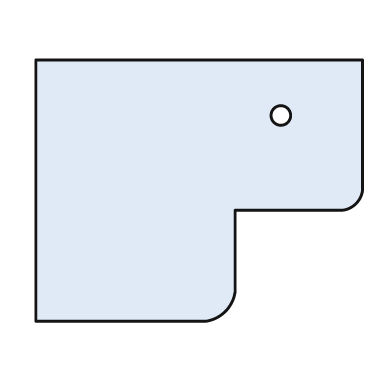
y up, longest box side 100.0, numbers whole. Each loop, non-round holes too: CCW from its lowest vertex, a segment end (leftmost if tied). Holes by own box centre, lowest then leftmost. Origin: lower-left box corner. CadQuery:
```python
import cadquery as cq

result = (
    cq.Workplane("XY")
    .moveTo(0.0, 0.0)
    .lineTo(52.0, 0.0)
    .threePointArc((58.0, 3.0), (61.0, 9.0))
    .lineTo(61.0, 34.0)
    .lineTo(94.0, 34.0)
    .threePointArc((98.0, 36.0), (100.0, 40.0))
    .lineTo(100.0, 80.0)
    .lineTo(0.0, 80.0)
    .close()
    .moveTo(75.0, 63.0)
    .circle(3.0)
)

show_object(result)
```